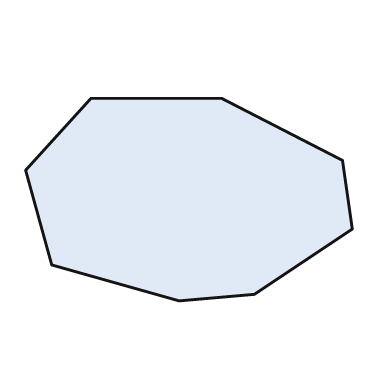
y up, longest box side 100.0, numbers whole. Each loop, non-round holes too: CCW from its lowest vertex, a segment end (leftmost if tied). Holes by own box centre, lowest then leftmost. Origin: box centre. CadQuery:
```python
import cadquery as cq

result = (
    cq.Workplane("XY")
    .moveTo(-3.0, -31.0)
    .lineTo(20.0, -29.0)
    .lineTo(50.0, -9.0)
    .lineTo(47.0, 12.0)
    .lineTo(10.0, 31.0)
    .lineTo(-30.0, 31.0)
    .lineTo(-50.0, 9.0)
    .lineTo(-42.0, -20.0)
    .close()
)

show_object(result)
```